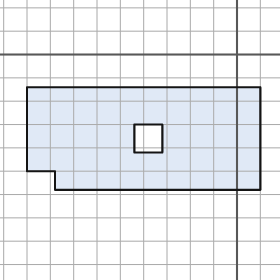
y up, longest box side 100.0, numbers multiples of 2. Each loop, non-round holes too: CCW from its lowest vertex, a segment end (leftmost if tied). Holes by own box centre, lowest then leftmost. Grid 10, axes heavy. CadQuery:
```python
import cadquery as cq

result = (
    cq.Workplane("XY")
    .moveTo(-78.0, -58.0)
    .lineTo(10.0, -58.0)
    .lineTo(10.0, -14.0)
    .lineTo(-90.0, -14.0)
    .lineTo(-90.0, -50.0)
    .lineTo(-78.0, -50.0)
    .close()
    .moveTo(-44.0, -42.0)
    .lineTo(-32.0, -42.0)
    .lineTo(-32.0, -30.0)
    .lineTo(-44.0, -30.0)
    .close()
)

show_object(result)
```